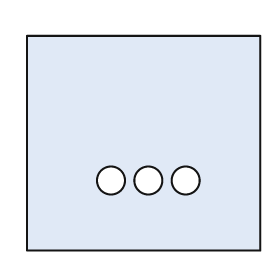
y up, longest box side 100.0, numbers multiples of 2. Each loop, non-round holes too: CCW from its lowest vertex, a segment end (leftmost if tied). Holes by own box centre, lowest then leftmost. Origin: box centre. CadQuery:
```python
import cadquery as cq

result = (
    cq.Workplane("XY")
    .moveTo(-50.0, -46.0)
    .lineTo(50.0, -46.0)
    .lineTo(50.0, 46.0)
    .lineTo(-50.0, 46.0)
    .close()
    .moveTo(-14.0, -16.0)
    .circle(6.0)
    .moveTo(2.0, -16.0)
    .circle(6.0)
    .moveTo(18.0, -16.0)
    .circle(6.0)
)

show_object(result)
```